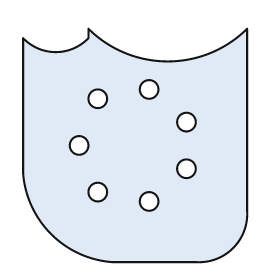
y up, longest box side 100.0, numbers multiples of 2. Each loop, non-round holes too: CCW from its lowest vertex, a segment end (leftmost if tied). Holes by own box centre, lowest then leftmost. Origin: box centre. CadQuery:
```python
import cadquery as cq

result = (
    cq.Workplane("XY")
    .moveTo(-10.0, -50.0)
    .lineTo(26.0, -50.0)
    .threePointArc((42.0, -44.0), (48.0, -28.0))
    .lineTo(48.0, 50.0)
    .threePointArc((14.0, 36.0), (-20.0, 50.0))
    .lineTo(-20.0, 46.0)
    .threePointArc((-34.0, 40.0), (-48.0, 46.0))
    .lineTo(-48.0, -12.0)
    .threePointArc((-36.0, -38.0), (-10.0, -50.0))
    .close()
    .moveTo(6.0, -24.0)
    .circle(4.0)
    .moveTo(-16.0, -20.0)
    .circle(4.0)
    .moveTo(22.0, -10.0)
    .circle(4.0)
    .moveTo(-24.0, 0.0)
    .circle(4.0)
    .moveTo(22.0, 10.0)
    .circle(4.0)
    .moveTo(-16.0, 20.0)
    .circle(4.0)
    .moveTo(6.0, 24.0)
    .circle(4.0)
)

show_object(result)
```